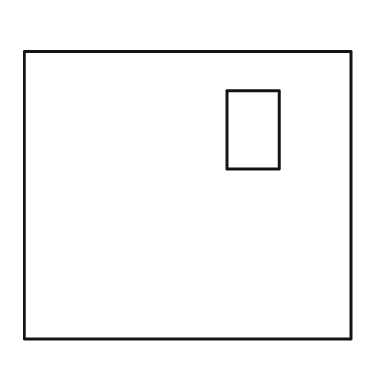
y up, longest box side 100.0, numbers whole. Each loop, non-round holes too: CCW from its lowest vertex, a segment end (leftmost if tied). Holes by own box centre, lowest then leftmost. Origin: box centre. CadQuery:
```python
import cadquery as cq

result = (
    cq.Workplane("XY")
    .moveTo(-50.0, -44.0)
    .lineTo(50.0, -44.0)
    .lineTo(50.0, 44.0)
    .lineTo(-50.0, 44.0)
    .close()
    .moveTo(12.0, 8.0)
    .lineTo(28.0, 8.0)
    .lineTo(28.0, 32.0)
    .lineTo(12.0, 32.0)
    .close()
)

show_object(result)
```